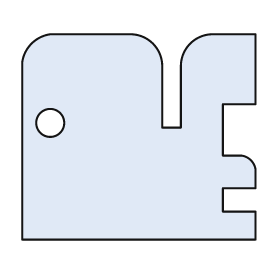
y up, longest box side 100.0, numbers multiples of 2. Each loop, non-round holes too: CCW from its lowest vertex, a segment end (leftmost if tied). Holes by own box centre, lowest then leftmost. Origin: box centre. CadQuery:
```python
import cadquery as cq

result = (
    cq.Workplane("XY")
    .moveTo(-50.0, -44.0)
    .lineTo(50.0, -44.0)
    .lineTo(50.0, -32.0)
    .lineTo(36.0, -32.0)
    .lineTo(36.0, -22.0)
    .lineTo(50.0, -22.0)
    .lineTo(50.0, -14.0)
    .threePointArc((48.0, -10.0), (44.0, -8.0))
    .lineTo(36.0, -8.0)
    .lineTo(36.0, 14.0)
    .lineTo(50.0, 14.0)
    .lineTo(50.0, 44.0)
    .lineTo(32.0, 44.0)
    .threePointArc((22.0, 40.0), (18.0, 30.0))
    .lineTo(18.0, 4.0)
    .lineTo(10.0, 4.0)
    .lineTo(10.0, 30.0)
    .threePointArc((6.0, 40.0), (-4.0, 44.0))
    .lineTo(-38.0, 44.0)
    .threePointArc((-46.0, 40.0), (-50.0, 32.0))
    .close()
    .moveTo(-38.0, 6.0)
    .circle(6.0)
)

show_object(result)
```